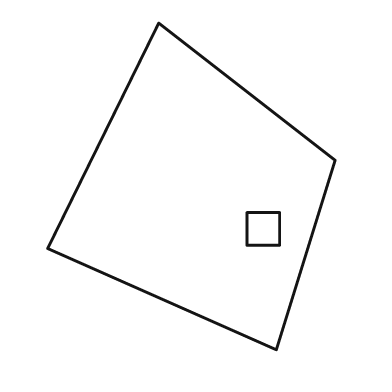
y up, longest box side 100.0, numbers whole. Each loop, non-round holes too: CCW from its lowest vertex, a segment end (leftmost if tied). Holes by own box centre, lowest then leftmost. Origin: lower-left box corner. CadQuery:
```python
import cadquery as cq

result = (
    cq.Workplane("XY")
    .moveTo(70.0, 0.0)
    .lineTo(88.0, 58.0)
    .lineTo(34.0, 100.0)
    .lineTo(0.0, 31.0)
    .close()
    .moveTo(61.0, 32.0)
    .lineTo(71.0, 32.0)
    .lineTo(71.0, 42.0)
    .lineTo(61.0, 42.0)
    .close()
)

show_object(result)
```